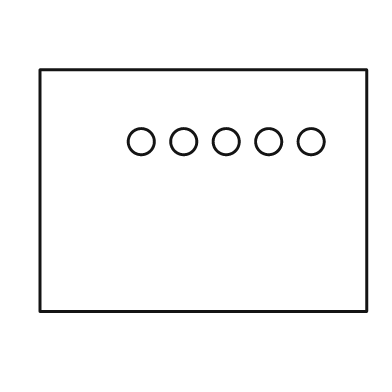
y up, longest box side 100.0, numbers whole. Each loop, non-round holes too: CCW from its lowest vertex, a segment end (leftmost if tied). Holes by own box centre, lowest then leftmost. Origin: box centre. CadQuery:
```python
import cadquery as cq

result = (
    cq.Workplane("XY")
    .moveTo(-50.0, -37.0)
    .lineTo(50.0, -37.0)
    .lineTo(50.0, 37.0)
    .lineTo(-50.0, 37.0)
    .close()
    .moveTo(-19.0, 15.0)
    .circle(4.0)
    .moveTo(-6.0, 15.0)
    .circle(4.0)
    .moveTo(7.0, 15.0)
    .circle(4.0)
    .moveTo(20.0, 15.0)
    .circle(4.0)
    .moveTo(33.0, 15.0)
    .circle(4.0)
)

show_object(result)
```